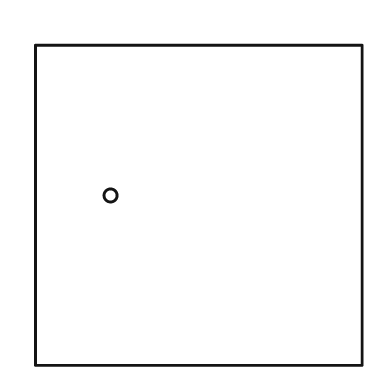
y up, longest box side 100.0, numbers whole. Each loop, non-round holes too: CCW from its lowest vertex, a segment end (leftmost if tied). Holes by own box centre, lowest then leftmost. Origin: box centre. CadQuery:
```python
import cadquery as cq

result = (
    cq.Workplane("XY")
    .moveTo(-50.0, -49.0)
    .lineTo(50.0, -49.0)
    .lineTo(50.0, 49.0)
    .lineTo(-50.0, 49.0)
    .close()
    .moveTo(-27.0, 3.0)
    .circle(2.0)
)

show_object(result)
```